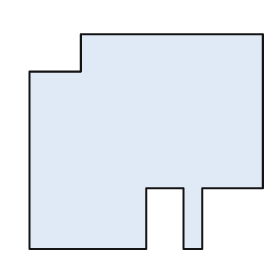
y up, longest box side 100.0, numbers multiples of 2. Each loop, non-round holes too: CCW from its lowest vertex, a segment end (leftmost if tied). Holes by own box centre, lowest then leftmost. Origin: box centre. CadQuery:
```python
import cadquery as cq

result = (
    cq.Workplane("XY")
    .moveTo(-50.0, -46.0)
    .lineTo(0.0, -46.0)
    .lineTo(0.0, -20.0)
    .lineTo(16.0, -20.0)
    .lineTo(16.0, -46.0)
    .lineTo(24.0, -46.0)
    .lineTo(24.0, -20.0)
    .lineTo(50.0, -20.0)
    .lineTo(50.0, 46.0)
    .lineTo(-28.0, 46.0)
    .lineTo(-28.0, 30.0)
    .lineTo(-50.0, 30.0)
    .close()
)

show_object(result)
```